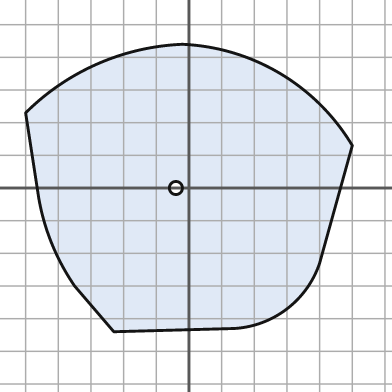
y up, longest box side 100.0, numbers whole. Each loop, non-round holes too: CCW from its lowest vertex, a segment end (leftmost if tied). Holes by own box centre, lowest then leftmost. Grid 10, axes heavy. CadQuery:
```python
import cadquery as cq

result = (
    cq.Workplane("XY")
    .moveTo(-23.0, -44.0)
    .lineTo(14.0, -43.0)
    .threePointArc((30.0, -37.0), (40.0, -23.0))
    .lineTo(50.0, 13.0)
    .threePointArc((28.0, 35.0), (-2.0, 44.0))
    .threePointArc((-28.0, 38.0), (-50.0, 23.0))
    .lineTo(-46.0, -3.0)
    .threePointArc((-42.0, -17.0), (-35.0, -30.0))
    .close()
    .moveTo(-4.0, 0.0)
    .circle(2.0)
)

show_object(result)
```